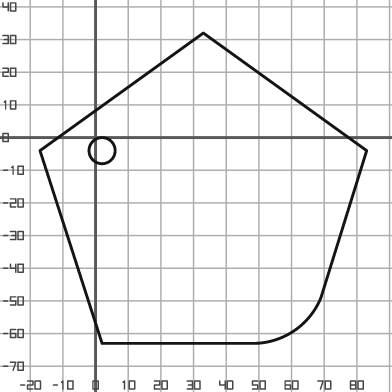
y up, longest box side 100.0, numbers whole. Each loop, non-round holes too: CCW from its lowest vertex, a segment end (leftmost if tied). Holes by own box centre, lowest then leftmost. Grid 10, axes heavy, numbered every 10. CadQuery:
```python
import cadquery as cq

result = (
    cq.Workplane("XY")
    .moveTo(2.0, -63.0)
    .lineTo(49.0, -63.0)
    .threePointArc((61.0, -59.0), (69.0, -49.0))
    .lineTo(83.0, -4.0)
    .lineTo(33.0, 32.0)
    .lineTo(-17.0, -4.0)
    .close()
    .moveTo(2.0, -4.0)
    .circle(4.0)
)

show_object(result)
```